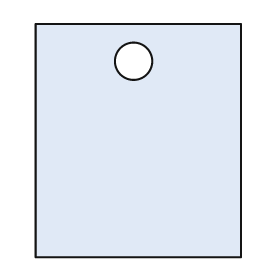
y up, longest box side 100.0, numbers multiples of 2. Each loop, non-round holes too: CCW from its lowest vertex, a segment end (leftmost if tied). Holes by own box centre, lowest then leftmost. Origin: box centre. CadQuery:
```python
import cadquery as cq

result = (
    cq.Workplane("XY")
    .moveTo(-44.0, -50.0)
    .lineTo(44.0, -50.0)
    .lineTo(44.0, 50.0)
    .lineTo(-44.0, 50.0)
    .close()
    .moveTo(-2.0, 34.0)
    .circle(8.0)
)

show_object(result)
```